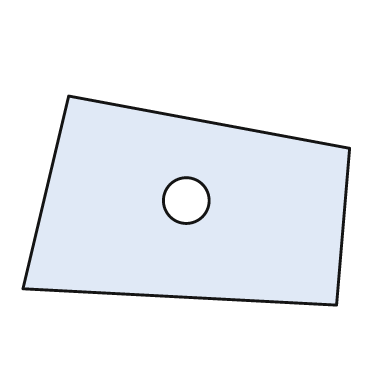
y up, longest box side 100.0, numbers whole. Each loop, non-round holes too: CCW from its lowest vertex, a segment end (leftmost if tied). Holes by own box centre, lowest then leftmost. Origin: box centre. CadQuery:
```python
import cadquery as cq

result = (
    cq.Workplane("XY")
    .moveTo(46.0, -32.0)
    .lineTo(50.0, 16.0)
    .lineTo(-36.0, 32.0)
    .lineTo(-50.0, -27.0)
    .close()
    .moveTo(0.0, 0.0)
    .circle(7.0)
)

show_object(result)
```